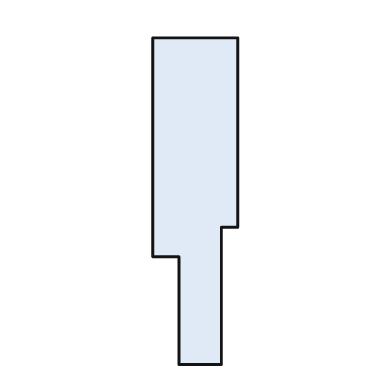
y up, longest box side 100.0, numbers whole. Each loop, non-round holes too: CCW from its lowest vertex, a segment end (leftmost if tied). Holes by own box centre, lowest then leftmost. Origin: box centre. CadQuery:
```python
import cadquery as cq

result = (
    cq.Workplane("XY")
    .moveTo(-5.0, -50.0)
    .lineTo(8.0, -50.0)
    .lineTo(8.0, -8.0)
    .lineTo(13.0, -8.0)
    .lineTo(13.0, 50.0)
    .lineTo(-13.0, 50.0)
    .lineTo(-13.0, -17.0)
    .lineTo(-5.0, -17.0)
    .close()
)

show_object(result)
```